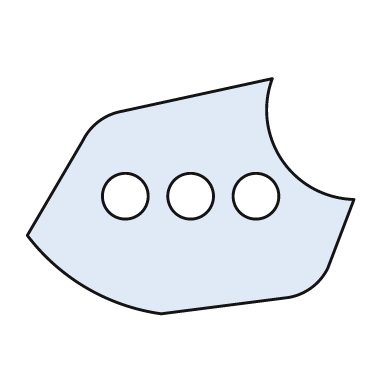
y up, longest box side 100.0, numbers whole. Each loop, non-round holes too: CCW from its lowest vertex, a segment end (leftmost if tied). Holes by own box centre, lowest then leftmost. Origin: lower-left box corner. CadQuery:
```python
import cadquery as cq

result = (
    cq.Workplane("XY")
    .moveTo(41.0, 0.0)
    .lineTo(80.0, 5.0)
    .threePointArc((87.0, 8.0), (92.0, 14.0))
    .lineTo(100.0, 35.0)
    .threePointArc((78.0, 47.0), (75.0, 72.0))
    .lineTo(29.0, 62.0)
    .threePointArc((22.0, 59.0), (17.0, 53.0))
    .lineTo(0.0, 24.0)
    .threePointArc((18.0, 8.0), (41.0, 0.0))
    .close()
    .moveTo(30.0, 36.0)
    .circle(7.0)
    .moveTo(50.0, 36.0)
    .circle(7.0)
    .moveTo(70.0, 36.0)
    .circle(7.0)
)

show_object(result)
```